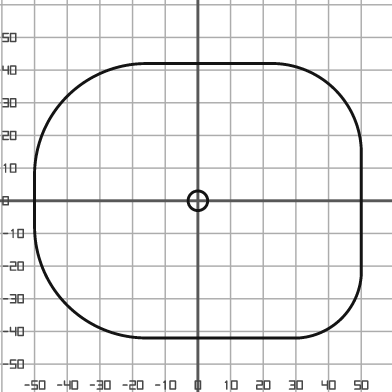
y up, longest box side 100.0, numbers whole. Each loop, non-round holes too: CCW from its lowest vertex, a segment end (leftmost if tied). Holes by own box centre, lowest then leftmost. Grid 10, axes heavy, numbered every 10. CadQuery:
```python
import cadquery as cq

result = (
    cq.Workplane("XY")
    .moveTo(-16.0, -42.0)
    .lineTo(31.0, -42.0)
    .threePointArc((44.0, -36.0), (50.0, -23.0))
    .lineTo(50.0, 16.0)
    .threePointArc((42.0, 34.0), (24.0, 42.0))
    .lineTo(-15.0, 42.0)
    .threePointArc((-40.0, 32.0), (-50.0, 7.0))
    .lineTo(-50.0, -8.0)
    .threePointArc((-40.0, -32.0), (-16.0, -42.0))
    .close()
    .moveTo(0.0, 0.0)
    .circle(3.0)
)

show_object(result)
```